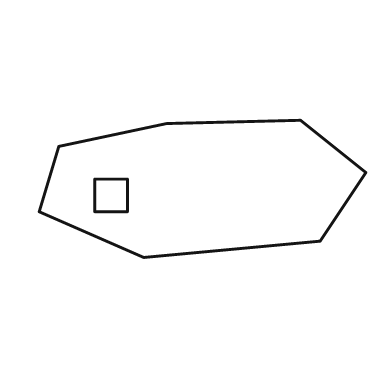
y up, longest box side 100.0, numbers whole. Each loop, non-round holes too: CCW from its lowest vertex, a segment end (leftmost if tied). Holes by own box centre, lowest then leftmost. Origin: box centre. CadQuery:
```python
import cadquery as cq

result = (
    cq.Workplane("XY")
    .moveTo(-18.0, -21.0)
    .lineTo(36.0, -16.0)
    .lineTo(50.0, 5.0)
    .lineTo(30.0, 21.0)
    .lineTo(-11.0, 20.0)
    .lineTo(-44.0, 13.0)
    .lineTo(-50.0, -7.0)
    .close()
    .moveTo(-33.0, -7.0)
    .lineTo(-23.0, -7.0)
    .lineTo(-23.0, 3.0)
    .lineTo(-33.0, 3.0)
    .close()
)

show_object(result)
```